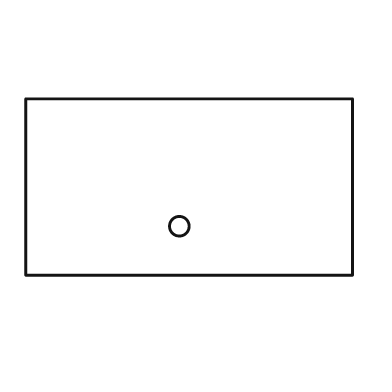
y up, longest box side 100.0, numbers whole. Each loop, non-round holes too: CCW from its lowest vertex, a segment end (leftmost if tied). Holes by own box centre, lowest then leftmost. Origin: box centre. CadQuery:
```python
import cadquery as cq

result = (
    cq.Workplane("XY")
    .moveTo(-50.0, -27.0)
    .lineTo(50.0, -27.0)
    .lineTo(50.0, 27.0)
    .lineTo(-50.0, 27.0)
    .close()
    .moveTo(-3.0, -12.0)
    .circle(3.0)
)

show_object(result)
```